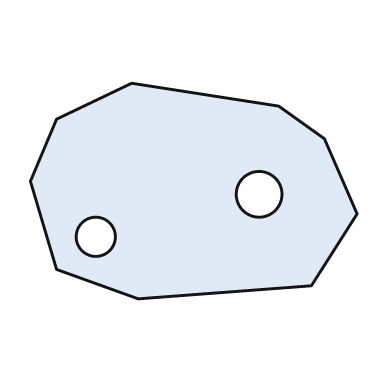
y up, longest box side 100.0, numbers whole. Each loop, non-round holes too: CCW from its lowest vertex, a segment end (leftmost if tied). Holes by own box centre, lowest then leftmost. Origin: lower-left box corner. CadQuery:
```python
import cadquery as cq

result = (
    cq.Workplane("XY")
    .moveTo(33.0, 0.0)
    .lineTo(86.0, 4.0)
    .lineTo(100.0, 26.0)
    .lineTo(90.0, 49.0)
    .lineTo(76.0, 59.0)
    .lineTo(31.0, 66.0)
    .lineTo(8.0, 55.0)
    .lineTo(0.0, 36.0)
    .lineTo(8.0, 9.0)
    .close()
    .moveTo(20.0, 19.0)
    .circle(6.0)
    .moveTo(70.0, 32.0)
    .circle(7.0)
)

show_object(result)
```